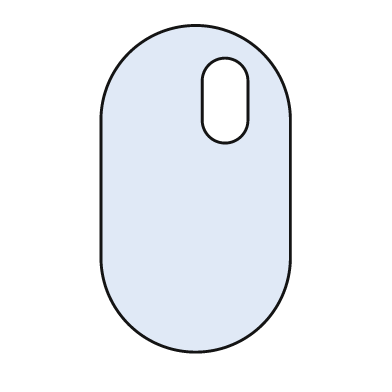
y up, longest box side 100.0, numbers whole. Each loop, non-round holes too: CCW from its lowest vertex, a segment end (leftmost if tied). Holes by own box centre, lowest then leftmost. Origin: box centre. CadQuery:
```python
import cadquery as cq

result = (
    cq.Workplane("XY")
    .moveTo(-29.0, -21.0)
    .threePointArc((0.0, -50.0), (29.0, -21.0))
    .lineTo(29.0, 21.0)
    .threePointArc((0.0, 50.0), (-29.0, 21.0))
    .close()
    .moveTo(2.0, 21.0)
    .threePointArc((9.0, 14.0), (16.0, 21.0))
    .lineTo(16.0, 33.0)
    .threePointArc((9.0, 40.0), (2.0, 33.0))
    .close()
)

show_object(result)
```